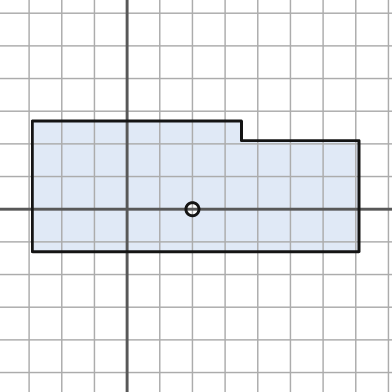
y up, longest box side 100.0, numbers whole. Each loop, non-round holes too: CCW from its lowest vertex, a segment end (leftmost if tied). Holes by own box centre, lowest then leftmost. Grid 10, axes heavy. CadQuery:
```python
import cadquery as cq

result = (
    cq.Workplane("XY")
    .moveTo(-29.0, -13.0)
    .lineTo(71.0, -13.0)
    .lineTo(71.0, 21.0)
    .lineTo(35.0, 21.0)
    .lineTo(35.0, 27.0)
    .lineTo(-29.0, 27.0)
    .close()
    .moveTo(20.0, 0.0)
    .circle(2.0)
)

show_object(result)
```